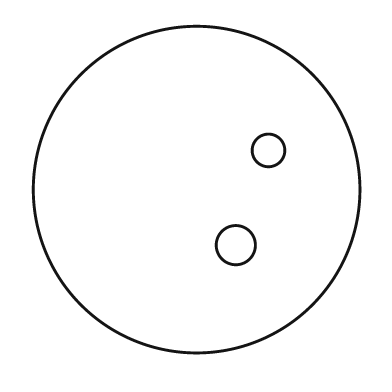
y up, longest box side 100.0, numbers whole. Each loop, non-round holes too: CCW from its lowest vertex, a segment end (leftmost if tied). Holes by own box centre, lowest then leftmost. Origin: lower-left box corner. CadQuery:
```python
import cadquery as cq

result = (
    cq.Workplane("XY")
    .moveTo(50.0, 50.0)
    .circle(50.0)
    .moveTo(62.0, 33.0)
    .circle(6.0)
    .moveTo(72.0, 62.0)
    .circle(5.0)
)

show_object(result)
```